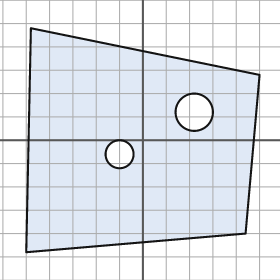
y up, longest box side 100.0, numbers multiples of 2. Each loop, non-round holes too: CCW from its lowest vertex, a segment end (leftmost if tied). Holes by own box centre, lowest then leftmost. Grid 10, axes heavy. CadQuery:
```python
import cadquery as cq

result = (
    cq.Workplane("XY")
    .moveTo(-50.0, -48.0)
    .lineTo(44.0, -40.0)
    .lineTo(50.0, 28.0)
    .lineTo(-48.0, 48.0)
    .close()
    .moveTo(-10.0, -6.0)
    .circle(6.0)
    .moveTo(22.0, 12.0)
    .circle(8.0)
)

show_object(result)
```